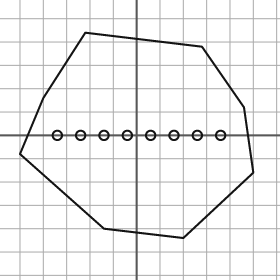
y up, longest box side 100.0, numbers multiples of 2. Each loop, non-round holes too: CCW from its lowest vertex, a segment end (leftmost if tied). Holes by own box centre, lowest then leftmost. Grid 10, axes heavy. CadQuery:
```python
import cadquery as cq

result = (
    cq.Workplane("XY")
    .moveTo(20.0, -44.0)
    .lineTo(50.0, -16.0)
    .lineTo(46.0, 12.0)
    .lineTo(28.0, 38.0)
    .lineTo(-22.0, 44.0)
    .lineTo(-40.0, 16.0)
    .lineTo(-50.0, -8.0)
    .lineTo(-14.0, -40.0)
    .close()
    .moveTo(-34.0, 0.0)
    .circle(2.0)
    .moveTo(-24.0, 0.0)
    .circle(2.0)
    .moveTo(-14.0, 0.0)
    .circle(2.0)
    .moveTo(-4.0, 0.0)
    .circle(2.0)
    .moveTo(6.0, 0.0)
    .circle(2.0)
    .moveTo(16.0, 0.0)
    .circle(2.0)
    .moveTo(26.0, 0.0)
    .circle(2.0)
    .moveTo(36.0, 0.0)
    .circle(2.0)
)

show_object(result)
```